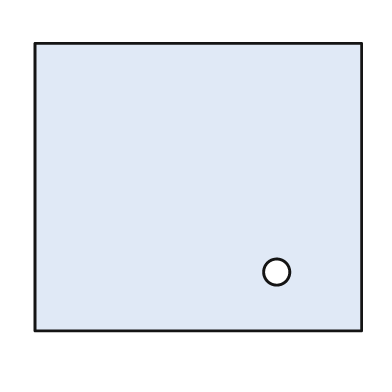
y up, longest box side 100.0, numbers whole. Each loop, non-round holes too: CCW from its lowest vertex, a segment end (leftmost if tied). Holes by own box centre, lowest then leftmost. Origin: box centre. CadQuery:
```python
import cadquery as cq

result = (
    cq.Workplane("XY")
    .moveTo(-50.0, -44.0)
    .lineTo(50.0, -44.0)
    .lineTo(50.0, 44.0)
    .lineTo(-50.0, 44.0)
    .close()
    .moveTo(24.0, -26.0)
    .circle(4.0)
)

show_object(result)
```